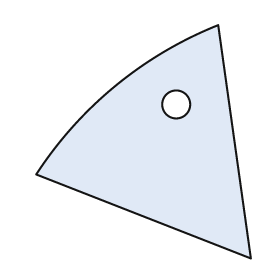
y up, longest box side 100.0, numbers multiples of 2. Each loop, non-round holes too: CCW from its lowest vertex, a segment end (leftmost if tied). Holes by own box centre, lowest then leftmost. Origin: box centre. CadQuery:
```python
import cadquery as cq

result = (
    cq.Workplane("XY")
    .moveTo(46.0, -50.0)
    .lineTo(32.0, 50.0)
    .threePointArc((-12.0, 24.0), (-46.0, -14.0))
    .close()
    .moveTo(14.0, 16.0)
    .circle(6.0)
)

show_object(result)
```